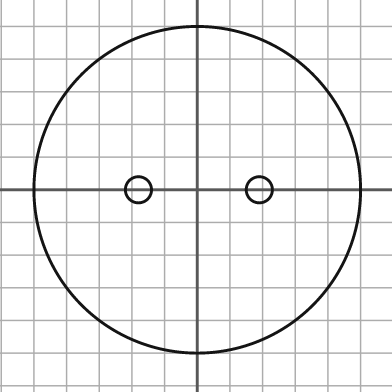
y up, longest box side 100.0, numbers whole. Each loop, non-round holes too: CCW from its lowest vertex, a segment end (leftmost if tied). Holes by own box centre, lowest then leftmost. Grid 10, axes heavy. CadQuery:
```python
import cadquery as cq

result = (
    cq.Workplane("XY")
    .moveTo(0.0, 0.0)
    .circle(50.0)
    .moveTo(-18.0, 0.0)
    .circle(4.0)
    .moveTo(19.0, 0.0)
    .circle(4.0)
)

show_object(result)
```